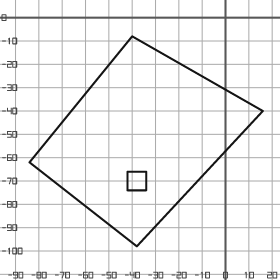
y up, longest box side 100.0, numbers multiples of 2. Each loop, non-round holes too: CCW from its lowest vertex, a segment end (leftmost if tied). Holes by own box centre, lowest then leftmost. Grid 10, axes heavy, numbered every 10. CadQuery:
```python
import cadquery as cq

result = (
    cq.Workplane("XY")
    .moveTo(-38.0, -98.0)
    .lineTo(16.0, -40.0)
    .lineTo(-40.0, -8.0)
    .lineTo(-84.0, -62.0)
    .close()
    .moveTo(-42.0, -74.0)
    .lineTo(-34.0, -74.0)
    .lineTo(-34.0, -66.0)
    .lineTo(-42.0, -66.0)
    .close()
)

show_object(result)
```